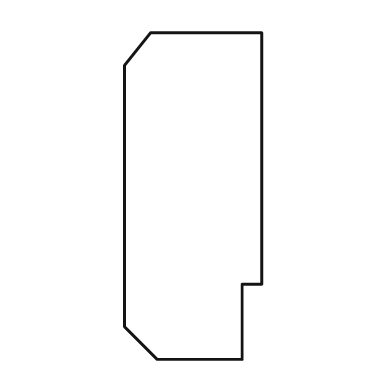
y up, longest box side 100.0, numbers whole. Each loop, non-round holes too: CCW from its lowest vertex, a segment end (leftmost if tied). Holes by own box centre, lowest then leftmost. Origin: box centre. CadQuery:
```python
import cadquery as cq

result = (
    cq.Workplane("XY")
    .moveTo(-11.0, -50.0)
    .lineTo(15.0, -50.0)
    .lineTo(15.0, -27.0)
    .lineTo(21.0, -27.0)
    .lineTo(21.0, 50.0)
    .lineTo(-13.0, 50.0)
    .lineTo(-21.0, 40.0)
    .lineTo(-21.0, -40.0)
    .close()
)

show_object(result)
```